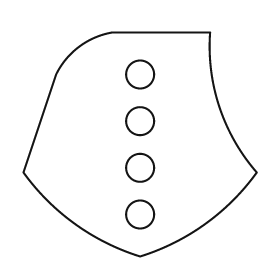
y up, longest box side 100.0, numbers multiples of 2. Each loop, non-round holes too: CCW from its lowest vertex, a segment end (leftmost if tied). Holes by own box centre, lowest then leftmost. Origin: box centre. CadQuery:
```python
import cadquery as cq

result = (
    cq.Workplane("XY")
    .moveTo(0.0, -48.0)
    .threePointArc((28.0, -34.0), (50.0, -12.0))
    .threePointArc((34.0, 16.0), (30.0, 48.0))
    .lineTo(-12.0, 48.0)
    .threePointArc((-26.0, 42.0), (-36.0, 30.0))
    .lineTo(-50.0, -12.0)
    .threePointArc((-28.0, -34.0), (0.0, -48.0))
    .close()
    .moveTo(0.0, -30.0)
    .circle(6.0)
    .moveTo(0.0, -10.0)
    .circle(6.0)
    .moveTo(0.0, 10.0)
    .circle(6.0)
    .moveTo(0.0, 30.0)
    .circle(6.0)
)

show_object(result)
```